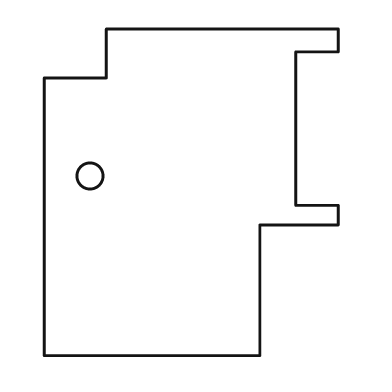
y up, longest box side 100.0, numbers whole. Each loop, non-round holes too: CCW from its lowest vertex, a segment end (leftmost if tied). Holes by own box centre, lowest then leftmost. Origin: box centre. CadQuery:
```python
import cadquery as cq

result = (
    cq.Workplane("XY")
    .moveTo(-45.0, -50.0)
    .lineTo(21.0, -50.0)
    .lineTo(21.0, -10.0)
    .lineTo(45.0, -10.0)
    .lineTo(45.0, -4.0)
    .lineTo(32.0, -4.0)
    .lineTo(32.0, 43.0)
    .lineTo(45.0, 43.0)
    .lineTo(45.0, 50.0)
    .lineTo(-26.0, 50.0)
    .lineTo(-26.0, 35.0)
    .lineTo(-45.0, 35.0)
    .close()
    .moveTo(-31.0, 5.0)
    .circle(4.0)
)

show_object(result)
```